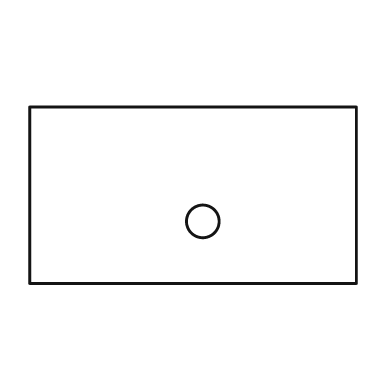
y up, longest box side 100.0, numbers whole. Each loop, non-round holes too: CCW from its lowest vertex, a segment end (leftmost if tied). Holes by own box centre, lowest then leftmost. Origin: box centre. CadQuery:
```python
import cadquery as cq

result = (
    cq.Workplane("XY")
    .moveTo(-50.0, -27.0)
    .lineTo(50.0, -27.0)
    .lineTo(50.0, 27.0)
    .lineTo(-50.0, 27.0)
    .close()
    .moveTo(3.0, -8.0)
    .circle(5.0)
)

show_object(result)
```